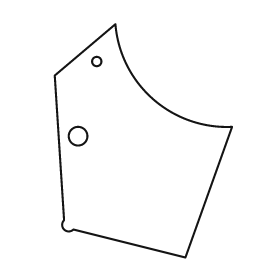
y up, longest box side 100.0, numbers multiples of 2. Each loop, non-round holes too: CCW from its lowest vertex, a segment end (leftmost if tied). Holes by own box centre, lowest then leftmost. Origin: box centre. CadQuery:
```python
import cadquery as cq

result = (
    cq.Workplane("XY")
    .moveTo(18.0, -50.0)
    .lineTo(38.0, 6.0)
    .threePointArc((4.0, 18.0), (-12.0, 50.0))
    .lineTo(-38.0, 28.0)
    .lineTo(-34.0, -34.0)
    .threePointArc((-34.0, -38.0), (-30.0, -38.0))
    .close()
    .moveTo(-28.0, 2.0)
    .circle(4.0)
    .moveTo(-20.0, 34.0)
    .circle(2.0)
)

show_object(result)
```